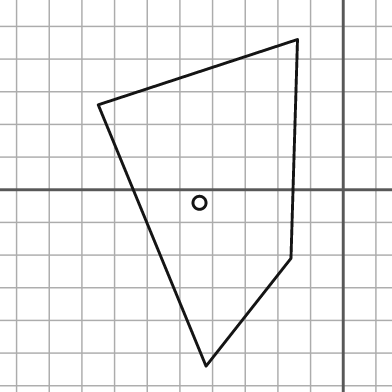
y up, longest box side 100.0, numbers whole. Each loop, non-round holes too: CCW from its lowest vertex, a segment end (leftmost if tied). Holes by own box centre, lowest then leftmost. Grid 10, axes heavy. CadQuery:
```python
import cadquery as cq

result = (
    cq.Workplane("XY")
    .moveTo(-42.0, -54.0)
    .lineTo(-16.0, -21.0)
    .lineTo(-14.0, 46.0)
    .lineTo(-75.0, 26.0)
    .close()
    .moveTo(-44.0, -4.0)
    .circle(2.0)
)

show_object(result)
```